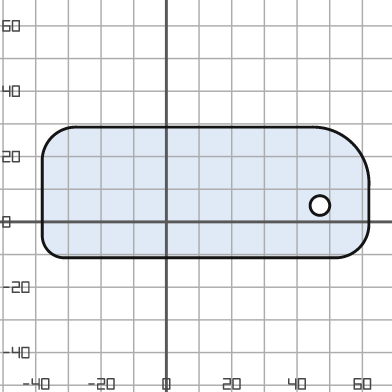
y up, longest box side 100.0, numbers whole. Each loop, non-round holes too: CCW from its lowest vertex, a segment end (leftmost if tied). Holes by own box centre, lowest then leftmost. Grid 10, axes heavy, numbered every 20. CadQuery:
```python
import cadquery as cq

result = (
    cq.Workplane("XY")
    .moveTo(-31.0, -11.0)
    .lineTo(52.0, -11.0)
    .threePointArc((59.0, -8.0), (62.0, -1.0))
    .lineTo(62.0, 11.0)
    .threePointArc((57.0, 24.0), (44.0, 29.0))
    .lineTo(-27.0, 29.0)
    .threePointArc((-35.0, 26.0), (-38.0, 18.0))
    .lineTo(-38.0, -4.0)
    .threePointArc((-36.0, -9.0), (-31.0, -11.0))
    .close()
    .moveTo(47.0, 5.0)
    .circle(3.0)
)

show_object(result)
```